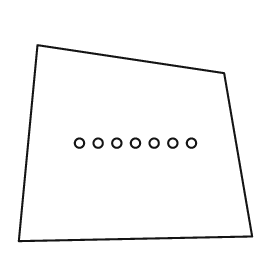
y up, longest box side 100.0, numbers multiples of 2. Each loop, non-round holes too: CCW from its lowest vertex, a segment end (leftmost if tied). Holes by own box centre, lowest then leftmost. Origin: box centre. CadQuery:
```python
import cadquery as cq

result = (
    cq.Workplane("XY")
    .moveTo(-50.0, -42.0)
    .lineTo(50.0, -40.0)
    .lineTo(38.0, 30.0)
    .lineTo(-42.0, 42.0)
    .close()
    .moveTo(-24.0, 0.0)
    .circle(2.0)
    .moveTo(-16.0, 0.0)
    .circle(2.0)
    .moveTo(-8.0, 0.0)
    .circle(2.0)
    .moveTo(0.0, 0.0)
    .circle(2.0)
    .moveTo(8.0, 0.0)
    .circle(2.0)
    .moveTo(16.0, 0.0)
    .circle(2.0)
    .moveTo(24.0, 0.0)
    .circle(2.0)
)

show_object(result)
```